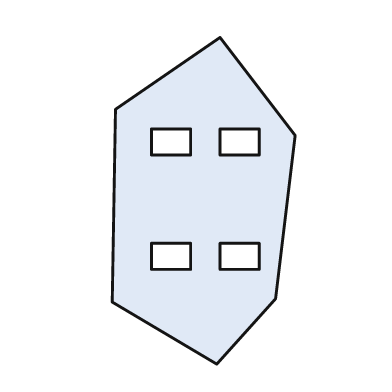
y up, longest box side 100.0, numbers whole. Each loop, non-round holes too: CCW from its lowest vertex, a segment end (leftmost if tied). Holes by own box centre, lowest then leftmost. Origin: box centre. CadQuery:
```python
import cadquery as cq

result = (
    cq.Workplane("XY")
    .moveTo(4.0, -50.0)
    .lineTo(22.0, -30.0)
    .lineTo(28.0, 20.0)
    .lineTo(5.0, 50.0)
    .lineTo(-27.0, 28.0)
    .lineTo(-28.0, -31.0)
    .close()
    .moveTo(-16.0, -21.0)
    .lineTo(-4.0, -21.0)
    .lineTo(-4.0, -13.0)
    .lineTo(-16.0, -13.0)
    .close()
    .moveTo(5.0, -21.0)
    .lineTo(17.0, -21.0)
    .lineTo(17.0, -13.0)
    .lineTo(5.0, -13.0)
    .close()
    .moveTo(-16.0, 14.0)
    .lineTo(-4.0, 14.0)
    .lineTo(-4.0, 22.0)
    .lineTo(-16.0, 22.0)
    .close()
    .moveTo(5.0, 14.0)
    .lineTo(17.0, 14.0)
    .lineTo(17.0, 22.0)
    .lineTo(5.0, 22.0)
    .close()
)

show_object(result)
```